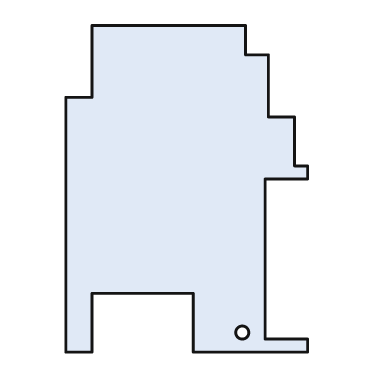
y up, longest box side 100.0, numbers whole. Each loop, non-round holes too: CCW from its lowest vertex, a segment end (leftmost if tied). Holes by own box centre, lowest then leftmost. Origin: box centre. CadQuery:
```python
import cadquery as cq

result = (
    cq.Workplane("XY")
    .moveTo(-37.0, -50.0)
    .lineTo(-29.0, -50.0)
    .lineTo(-29.0, -32.0)
    .lineTo(2.0, -32.0)
    .lineTo(2.0, -50.0)
    .lineTo(37.0, -50.0)
    .lineTo(37.0, -46.0)
    .lineTo(24.0, -46.0)
    .lineTo(24.0, 3.0)
    .lineTo(37.0, 3.0)
    .lineTo(37.0, 7.0)
    .lineTo(33.0, 7.0)
    .lineTo(33.0, 22.0)
    .lineTo(25.0, 22.0)
    .lineTo(25.0, 41.0)
    .lineTo(18.0, 41.0)
    .lineTo(18.0, 50.0)
    .lineTo(-29.0, 50.0)
    .lineTo(-29.0, 28.0)
    .lineTo(-37.0, 28.0)
    .close()
    .moveTo(17.0, -44.0)
    .circle(2.0)
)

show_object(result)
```